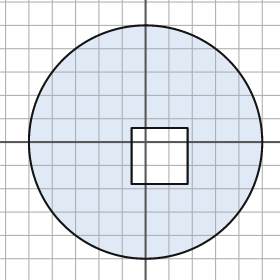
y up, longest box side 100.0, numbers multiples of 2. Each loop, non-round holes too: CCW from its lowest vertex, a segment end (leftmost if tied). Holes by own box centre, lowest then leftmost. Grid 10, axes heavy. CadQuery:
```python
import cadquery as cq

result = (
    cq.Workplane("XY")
    .moveTo(0.0, 0.0)
    .circle(50.0)
    .moveTo(-6.0, -18.0)
    .lineTo(18.0, -18.0)
    .lineTo(18.0, 6.0)
    .lineTo(-6.0, 6.0)
    .close()
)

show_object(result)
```